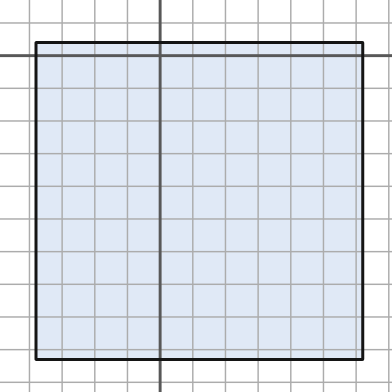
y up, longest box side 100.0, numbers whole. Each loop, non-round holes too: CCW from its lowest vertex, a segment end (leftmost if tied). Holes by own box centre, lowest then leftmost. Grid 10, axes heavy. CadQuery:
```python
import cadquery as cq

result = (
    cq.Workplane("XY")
    .moveTo(-38.0, -93.0)
    .lineTo(62.0, -93.0)
    .lineTo(62.0, 4.0)
    .lineTo(-38.0, 4.0)
    .close()
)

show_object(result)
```